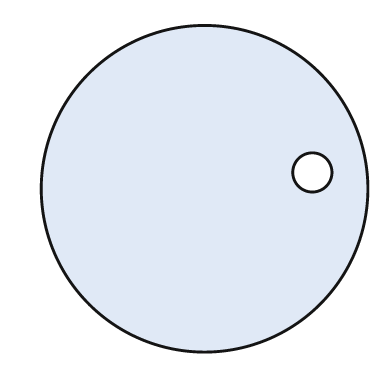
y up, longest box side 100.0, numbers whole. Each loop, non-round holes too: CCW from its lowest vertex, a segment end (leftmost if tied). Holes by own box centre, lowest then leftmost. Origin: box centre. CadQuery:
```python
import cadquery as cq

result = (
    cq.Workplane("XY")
    .moveTo(0.0, 0.0)
    .circle(50.0)
    .moveTo(33.0, 5.0)
    .circle(6.0)
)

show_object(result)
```